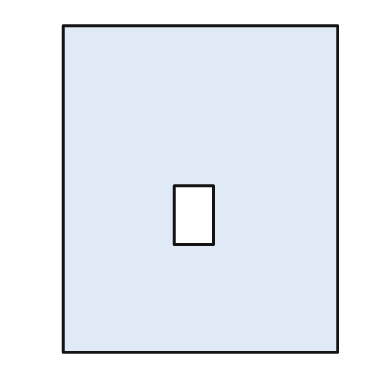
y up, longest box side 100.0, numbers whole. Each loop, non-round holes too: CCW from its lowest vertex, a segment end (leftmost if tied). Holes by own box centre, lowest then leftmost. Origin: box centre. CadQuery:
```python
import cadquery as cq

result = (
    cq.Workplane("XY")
    .moveTo(-42.0, -50.0)
    .lineTo(42.0, -50.0)
    .lineTo(42.0, 50.0)
    .lineTo(-42.0, 50.0)
    .close()
    .moveTo(-8.0, -17.0)
    .lineTo(4.0, -17.0)
    .lineTo(4.0, 1.0)
    .lineTo(-8.0, 1.0)
    .close()
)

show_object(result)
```